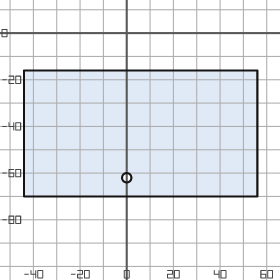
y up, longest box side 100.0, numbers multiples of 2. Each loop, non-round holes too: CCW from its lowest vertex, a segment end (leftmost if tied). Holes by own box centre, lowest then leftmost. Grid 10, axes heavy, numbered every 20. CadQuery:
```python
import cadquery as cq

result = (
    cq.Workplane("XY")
    .moveTo(-44.0, -70.0)
    .lineTo(56.0, -70.0)
    .lineTo(56.0, -16.0)
    .lineTo(-44.0, -16.0)
    .close()
    .moveTo(0.0, -62.0)
    .circle(2.0)
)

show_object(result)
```